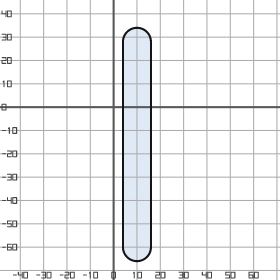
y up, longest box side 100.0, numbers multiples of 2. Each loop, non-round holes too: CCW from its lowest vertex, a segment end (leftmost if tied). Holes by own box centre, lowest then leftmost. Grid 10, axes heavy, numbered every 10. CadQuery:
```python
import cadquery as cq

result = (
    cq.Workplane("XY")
    .moveTo(4.0, -60.0)
    .threePointArc((10.0, -66.0), (16.0, -60.0))
    .lineTo(16.0, 28.0)
    .threePointArc((10.0, 34.0), (4.0, 28.0))
    .close()
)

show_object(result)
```